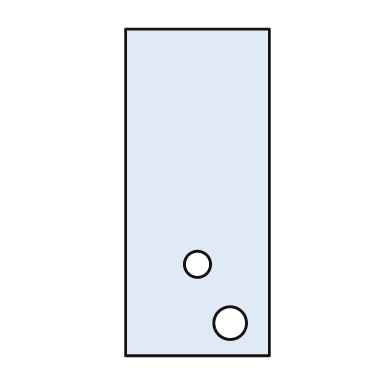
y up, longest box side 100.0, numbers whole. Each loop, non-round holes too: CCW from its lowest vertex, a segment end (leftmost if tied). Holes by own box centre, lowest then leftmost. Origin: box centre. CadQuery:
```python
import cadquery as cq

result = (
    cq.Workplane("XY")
    .moveTo(-22.0, -50.0)
    .lineTo(22.0, -50.0)
    .lineTo(22.0, 50.0)
    .lineTo(-22.0, 50.0)
    .close()
    .moveTo(10.0, -40.0)
    .circle(5.0)
    .moveTo(0.0, -22.0)
    .circle(4.0)
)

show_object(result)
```